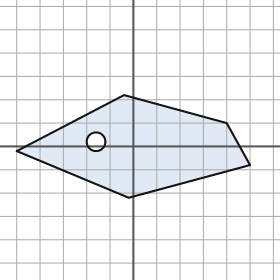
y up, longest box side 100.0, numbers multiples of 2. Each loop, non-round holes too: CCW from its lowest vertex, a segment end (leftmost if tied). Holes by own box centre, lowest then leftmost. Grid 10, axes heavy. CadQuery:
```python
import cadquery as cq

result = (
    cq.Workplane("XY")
    .moveTo(-2.0, -22.0)
    .lineTo(50.0, -8.0)
    .lineTo(40.0, 10.0)
    .lineTo(-4.0, 22.0)
    .lineTo(-50.0, -2.0)
    .close()
    .moveTo(-16.0, 2.0)
    .circle(4.0)
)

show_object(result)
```